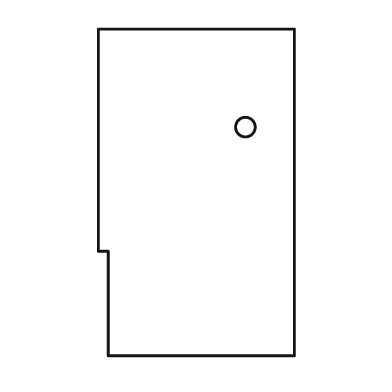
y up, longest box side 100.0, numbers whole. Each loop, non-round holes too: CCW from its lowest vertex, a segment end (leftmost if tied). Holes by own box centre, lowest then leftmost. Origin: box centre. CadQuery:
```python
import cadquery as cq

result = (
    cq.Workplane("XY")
    .moveTo(-27.0, -50.0)
    .lineTo(30.0, -50.0)
    .lineTo(30.0, 50.0)
    .lineTo(-30.0, 50.0)
    .lineTo(-30.0, -18.0)
    .lineTo(-27.0, -18.0)
    .close()
    .moveTo(15.0, 20.0)
    .circle(3.0)
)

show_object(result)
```